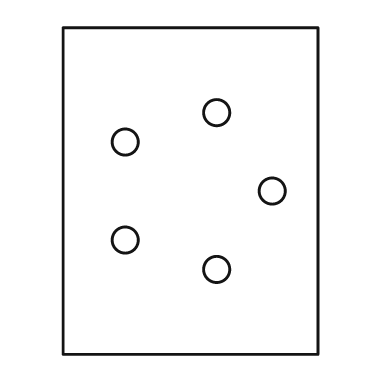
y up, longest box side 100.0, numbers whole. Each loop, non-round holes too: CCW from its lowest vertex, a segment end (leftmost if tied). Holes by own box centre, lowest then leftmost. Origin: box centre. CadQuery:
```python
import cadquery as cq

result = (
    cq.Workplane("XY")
    .moveTo(-39.0, -50.0)
    .lineTo(39.0, -50.0)
    .lineTo(39.0, 50.0)
    .lineTo(-39.0, 50.0)
    .close()
    .moveTo(8.0, -24.0)
    .circle(4.0)
    .moveTo(-20.0, -15.0)
    .circle(4.0)
    .moveTo(25.0, 0.0)
    .circle(4.0)
    .moveTo(-20.0, 15.0)
    .circle(4.0)
    .moveTo(8.0, 24.0)
    .circle(4.0)
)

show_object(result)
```